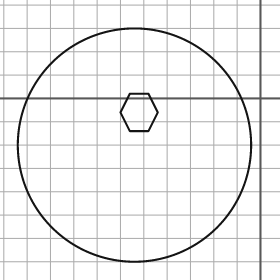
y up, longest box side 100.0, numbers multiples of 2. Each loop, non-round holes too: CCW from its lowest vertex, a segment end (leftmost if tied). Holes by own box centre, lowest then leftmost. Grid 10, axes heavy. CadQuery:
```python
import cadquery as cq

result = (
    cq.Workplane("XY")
    .moveTo(-54.0, -20.0)
    .circle(50.0)
    .moveTo(-56.0, -14.0)
    .lineTo(-48.0, -14.0)
    .lineTo(-44.0, -6.0)
    .lineTo(-48.0, 2.0)
    .lineTo(-56.0, 2.0)
    .lineTo(-60.0, -6.0)
    .close()
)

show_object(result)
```